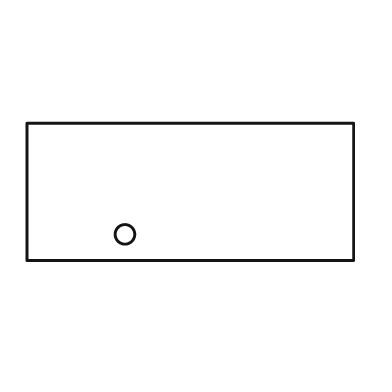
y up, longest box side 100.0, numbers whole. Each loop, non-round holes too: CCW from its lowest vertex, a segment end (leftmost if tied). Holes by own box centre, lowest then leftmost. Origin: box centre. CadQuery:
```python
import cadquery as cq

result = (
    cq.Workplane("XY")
    .moveTo(-50.0, -21.0)
    .lineTo(50.0, -21.0)
    .lineTo(50.0, 21.0)
    .lineTo(-50.0, 21.0)
    .close()
    .moveTo(-20.0, -13.0)
    .circle(3.0)
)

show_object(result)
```